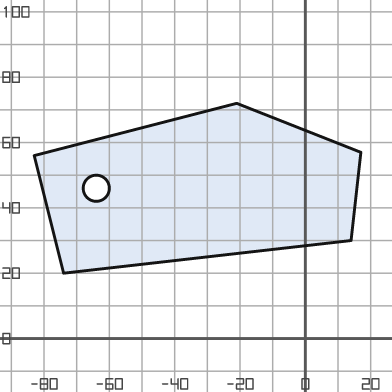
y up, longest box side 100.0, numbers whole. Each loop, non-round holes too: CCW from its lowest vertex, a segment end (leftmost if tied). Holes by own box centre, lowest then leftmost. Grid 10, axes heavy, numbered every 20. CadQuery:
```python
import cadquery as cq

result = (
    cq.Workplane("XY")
    .moveTo(-74.0, 20.0)
    .lineTo(14.0, 30.0)
    .lineTo(17.0, 57.0)
    .lineTo(-21.0, 72.0)
    .lineTo(-83.0, 56.0)
    .close()
    .moveTo(-64.0, 46.0)
    .circle(4.0)
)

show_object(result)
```